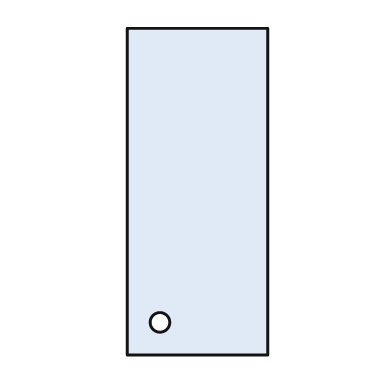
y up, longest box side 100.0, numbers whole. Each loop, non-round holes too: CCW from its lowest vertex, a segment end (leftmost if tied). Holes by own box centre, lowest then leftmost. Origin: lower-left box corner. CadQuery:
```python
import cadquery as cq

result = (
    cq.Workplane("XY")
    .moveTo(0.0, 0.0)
    .lineTo(43.0, 0.0)
    .lineTo(43.0, 100.0)
    .lineTo(0.0, 100.0)
    .close()
    .moveTo(10.0, 10.0)
    .circle(3.0)
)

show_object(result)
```